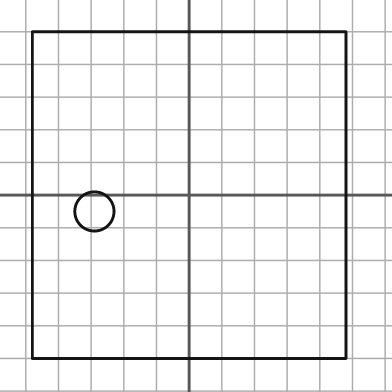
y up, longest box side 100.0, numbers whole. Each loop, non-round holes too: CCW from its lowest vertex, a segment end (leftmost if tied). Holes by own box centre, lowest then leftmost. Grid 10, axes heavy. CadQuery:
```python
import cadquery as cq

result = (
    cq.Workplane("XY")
    .moveTo(-48.0, -50.0)
    .lineTo(48.0, -50.0)
    .lineTo(48.0, 50.0)
    .lineTo(-48.0, 50.0)
    .close()
    .moveTo(-29.0, -5.0)
    .circle(6.0)
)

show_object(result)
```